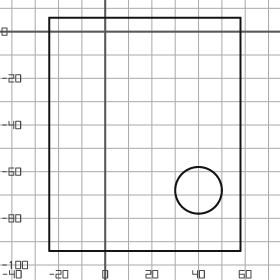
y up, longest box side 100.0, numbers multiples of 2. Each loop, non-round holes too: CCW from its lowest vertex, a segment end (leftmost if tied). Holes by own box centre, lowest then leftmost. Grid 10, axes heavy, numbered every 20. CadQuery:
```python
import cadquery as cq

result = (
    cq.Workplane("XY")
    .moveTo(-24.0, -94.0)
    .lineTo(58.0, -94.0)
    .lineTo(58.0, 6.0)
    .lineTo(-24.0, 6.0)
    .close()
    .moveTo(40.0, -68.0)
    .circle(10.0)
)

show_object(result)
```